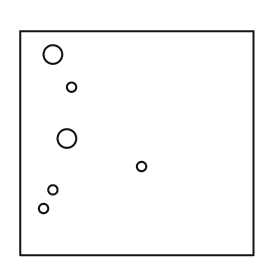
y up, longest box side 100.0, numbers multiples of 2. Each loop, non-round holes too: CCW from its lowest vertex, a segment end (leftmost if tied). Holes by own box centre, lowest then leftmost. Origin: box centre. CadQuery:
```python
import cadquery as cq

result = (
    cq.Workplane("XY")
    .moveTo(-50.0, -48.0)
    .lineTo(50.0, -48.0)
    .lineTo(50.0, 48.0)
    .lineTo(-50.0, 48.0)
    .close()
    .moveTo(-40.0, -28.0)
    .circle(2.0)
    .moveTo(-36.0, -20.0)
    .circle(2.0)
    .moveTo(2.0, -10.0)
    .circle(2.0)
    .moveTo(-30.0, 2.0)
    .circle(4.0)
    .moveTo(-28.0, 24.0)
    .circle(2.0)
    .moveTo(-36.0, 38.0)
    .circle(4.0)
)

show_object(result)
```